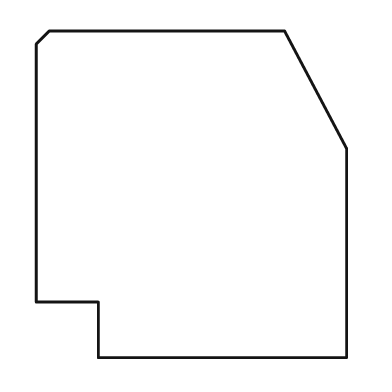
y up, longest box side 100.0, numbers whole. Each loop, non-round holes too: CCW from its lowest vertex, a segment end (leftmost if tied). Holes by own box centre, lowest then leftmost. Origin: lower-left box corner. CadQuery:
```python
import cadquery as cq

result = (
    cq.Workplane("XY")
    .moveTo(19.0, 0.0)
    .lineTo(95.0, 0.0)
    .lineTo(95.0, 64.0)
    .lineTo(76.0, 100.0)
    .lineTo(4.0, 100.0)
    .lineTo(0.0, 96.0)
    .lineTo(0.0, 17.0)
    .lineTo(19.0, 17.0)
    .close()
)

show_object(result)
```